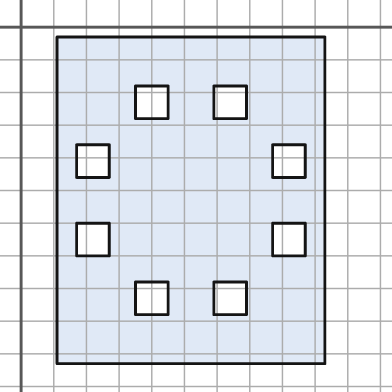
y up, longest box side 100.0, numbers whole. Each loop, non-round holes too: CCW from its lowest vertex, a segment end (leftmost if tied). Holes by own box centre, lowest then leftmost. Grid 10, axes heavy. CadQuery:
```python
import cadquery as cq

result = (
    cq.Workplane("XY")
    .moveTo(11.0, -103.0)
    .lineTo(93.0, -103.0)
    .lineTo(93.0, -3.0)
    .lineTo(11.0, -3.0)
    .close()
    .moveTo(35.0, -88.0)
    .lineTo(45.0, -88.0)
    .lineTo(45.0, -78.0)
    .lineTo(35.0, -78.0)
    .close()
    .moveTo(59.0, -88.0)
    .lineTo(69.0, -88.0)
    .lineTo(69.0, -78.0)
    .lineTo(59.0, -78.0)
    .close()
    .moveTo(17.0, -70.0)
    .lineTo(27.0, -70.0)
    .lineTo(27.0, -60.0)
    .lineTo(17.0, -60.0)
    .close()
    .moveTo(77.0, -70.0)
    .lineTo(87.0, -70.0)
    .lineTo(87.0, -60.0)
    .lineTo(77.0, -60.0)
    .close()
    .moveTo(17.0, -46.0)
    .lineTo(27.0, -46.0)
    .lineTo(27.0, -36.0)
    .lineTo(17.0, -36.0)
    .close()
    .moveTo(77.0, -46.0)
    .lineTo(87.0, -46.0)
    .lineTo(87.0, -36.0)
    .lineTo(77.0, -36.0)
    .close()
    .moveTo(35.0, -28.0)
    .lineTo(45.0, -28.0)
    .lineTo(45.0, -18.0)
    .lineTo(35.0, -18.0)
    .close()
    .moveTo(59.0, -28.0)
    .lineTo(69.0, -28.0)
    .lineTo(69.0, -18.0)
    .lineTo(59.0, -18.0)
    .close()
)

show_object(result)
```